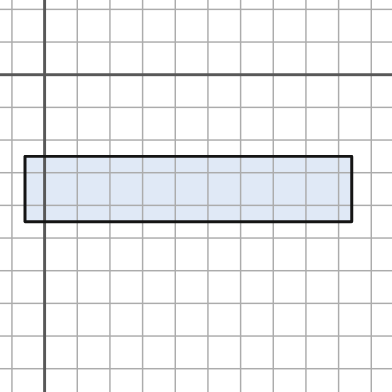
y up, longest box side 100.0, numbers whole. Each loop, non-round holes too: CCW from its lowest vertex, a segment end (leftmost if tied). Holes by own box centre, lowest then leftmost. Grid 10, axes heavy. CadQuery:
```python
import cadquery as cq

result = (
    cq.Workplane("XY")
    .moveTo(-6.0, -45.0)
    .lineTo(94.0, -45.0)
    .lineTo(94.0, -25.0)
    .lineTo(-6.0, -25.0)
    .close()
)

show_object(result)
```